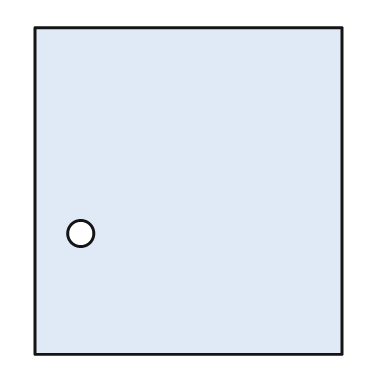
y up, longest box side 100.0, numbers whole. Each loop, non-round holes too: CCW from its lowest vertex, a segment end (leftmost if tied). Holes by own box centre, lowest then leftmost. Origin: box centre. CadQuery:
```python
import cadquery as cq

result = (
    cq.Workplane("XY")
    .moveTo(-47.0, -50.0)
    .lineTo(47.0, -50.0)
    .lineTo(47.0, 50.0)
    .lineTo(-47.0, 50.0)
    .close()
    .moveTo(-33.0, -13.0)
    .circle(4.0)
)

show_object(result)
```